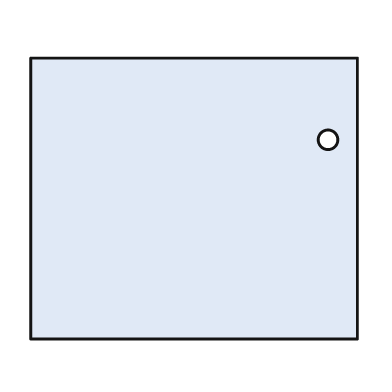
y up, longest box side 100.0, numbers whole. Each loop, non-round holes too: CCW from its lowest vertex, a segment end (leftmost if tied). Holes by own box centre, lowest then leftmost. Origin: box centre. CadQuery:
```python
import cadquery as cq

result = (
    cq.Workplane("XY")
    .moveTo(-50.0, -43.0)
    .lineTo(50.0, -43.0)
    .lineTo(50.0, 43.0)
    .lineTo(-50.0, 43.0)
    .close()
    .moveTo(41.0, 18.0)
    .circle(3.0)
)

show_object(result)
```